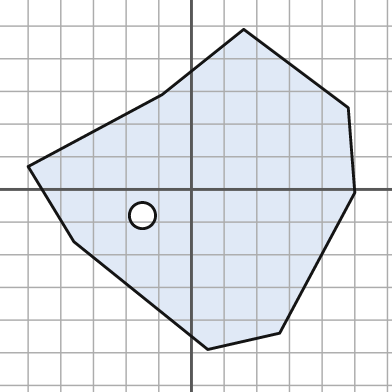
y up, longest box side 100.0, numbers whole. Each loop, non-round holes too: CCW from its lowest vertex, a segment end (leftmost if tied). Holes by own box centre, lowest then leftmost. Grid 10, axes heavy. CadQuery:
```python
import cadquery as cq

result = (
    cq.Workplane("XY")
    .moveTo(5.0, -49.0)
    .lineTo(27.0, -44.0)
    .lineTo(50.0, -1.0)
    .lineTo(48.0, 25.0)
    .lineTo(16.0, 49.0)
    .lineTo(-9.0, 29.0)
    .lineTo(-50.0, 7.0)
    .lineTo(-36.0, -16.0)
    .close()
    .moveTo(-15.0, -8.0)
    .circle(4.0)
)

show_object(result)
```